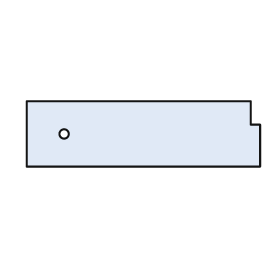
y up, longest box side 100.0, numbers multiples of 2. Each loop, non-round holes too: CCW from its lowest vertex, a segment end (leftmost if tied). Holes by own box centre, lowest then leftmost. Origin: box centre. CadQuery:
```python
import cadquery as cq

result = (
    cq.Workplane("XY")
    .moveTo(-50.0, -14.0)
    .lineTo(50.0, -14.0)
    .lineTo(50.0, 4.0)
    .lineTo(46.0, 4.0)
    .lineTo(46.0, 14.0)
    .lineTo(-50.0, 14.0)
    .close()
    .moveTo(-34.0, 0.0)
    .circle(2.0)
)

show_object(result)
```